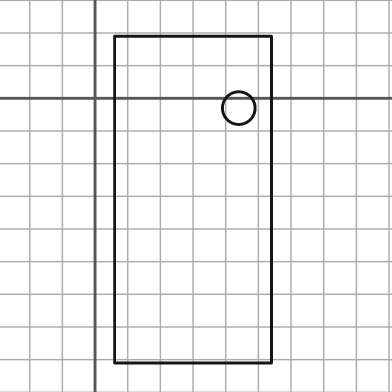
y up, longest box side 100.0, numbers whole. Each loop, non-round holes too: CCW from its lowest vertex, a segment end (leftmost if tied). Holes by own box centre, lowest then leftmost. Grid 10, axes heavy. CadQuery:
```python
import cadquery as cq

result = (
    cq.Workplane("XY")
    .moveTo(6.0, -81.0)
    .lineTo(54.0, -81.0)
    .lineTo(54.0, 19.0)
    .lineTo(6.0, 19.0)
    .close()
    .moveTo(44.0, -3.0)
    .circle(5.0)
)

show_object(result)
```